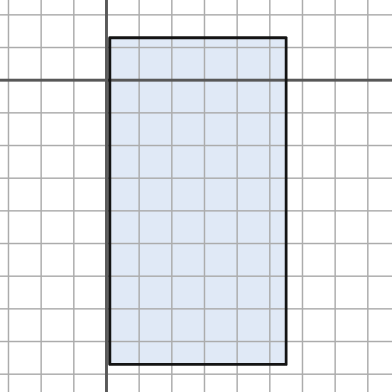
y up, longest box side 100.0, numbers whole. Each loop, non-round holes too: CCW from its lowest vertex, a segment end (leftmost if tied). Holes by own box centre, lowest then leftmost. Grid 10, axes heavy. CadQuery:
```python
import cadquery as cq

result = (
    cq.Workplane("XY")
    .moveTo(1.0, -87.0)
    .lineTo(55.0, -87.0)
    .lineTo(55.0, 13.0)
    .lineTo(1.0, 13.0)
    .close()
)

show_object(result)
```